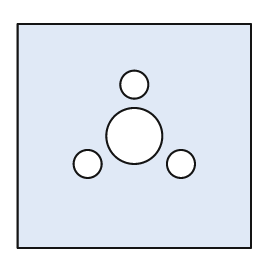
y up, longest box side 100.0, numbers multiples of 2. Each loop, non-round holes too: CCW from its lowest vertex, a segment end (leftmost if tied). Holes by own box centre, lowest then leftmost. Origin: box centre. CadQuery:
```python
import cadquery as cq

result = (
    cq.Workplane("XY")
    .moveTo(-50.0, -48.0)
    .lineTo(50.0, -48.0)
    .lineTo(50.0, 48.0)
    .lineTo(-50.0, 48.0)
    .close()
    .moveTo(-20.0, -12.0)
    .circle(6.0)
    .moveTo(20.0, -12.0)
    .circle(6.0)
    .moveTo(0.0, 0.0)
    .circle(12.0)
    .moveTo(0.0, 22.0)
    .circle(6.0)
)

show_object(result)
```